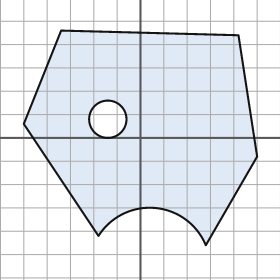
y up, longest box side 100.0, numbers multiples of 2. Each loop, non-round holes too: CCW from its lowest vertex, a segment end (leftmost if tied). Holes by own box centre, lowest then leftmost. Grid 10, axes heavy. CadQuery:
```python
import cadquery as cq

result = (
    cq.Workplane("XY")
    .moveTo(28.0, -46.0)
    .lineTo(50.0, -8.0)
    .lineTo(42.0, 44.0)
    .lineTo(-34.0, 46.0)
    .lineTo(-50.0, 6.0)
    .lineTo(-18.0, -42.0)
    .threePointArc((6.0, -30.0), (28.0, -46.0))
    .close()
    .moveTo(-14.0, 8.0)
    .circle(8.0)
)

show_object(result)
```